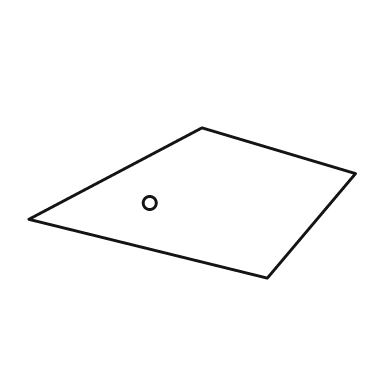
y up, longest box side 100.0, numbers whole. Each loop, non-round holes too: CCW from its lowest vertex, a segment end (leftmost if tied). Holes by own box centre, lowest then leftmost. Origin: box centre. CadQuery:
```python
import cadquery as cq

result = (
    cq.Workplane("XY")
    .moveTo(23.0, -23.0)
    .lineTo(50.0, 9.0)
    .lineTo(3.0, 23.0)
    .lineTo(-50.0, -5.0)
    .close()
    .moveTo(-13.0, 0.0)
    .circle(2.0)
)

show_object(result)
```